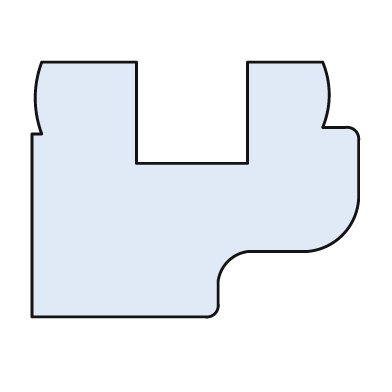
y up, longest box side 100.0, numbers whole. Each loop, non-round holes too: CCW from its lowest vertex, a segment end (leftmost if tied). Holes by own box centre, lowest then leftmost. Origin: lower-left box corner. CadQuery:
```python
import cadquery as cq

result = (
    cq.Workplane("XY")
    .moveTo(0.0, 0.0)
    .lineTo(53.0, 0.0)
    .threePointArc((56.0, 1.0), (57.0, 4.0))
    .lineTo(57.0, 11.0)
    .threePointArc((60.0, 17.0), (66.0, 20.0))
    .lineTo(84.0, 20.0)
    .threePointArc((95.0, 25.0), (100.0, 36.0))
    .lineTo(100.0, 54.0)
    .threePointArc((99.0, 57.0), (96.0, 58.0))
    .lineTo(89.0, 58.0)
    .threePointArc((91.0, 68.0), (89.0, 78.0))
    .lineTo(66.0, 78.0)
    .lineTo(66.0, 47.0)
    .lineTo(32.0, 47.0)
    .lineTo(32.0, 78.0)
    .lineTo(3.0, 78.0)
    .threePointArc((1.0, 67.0), (3.0, 56.0))
    .lineTo(0.0, 56.0)
    .close()
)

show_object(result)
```